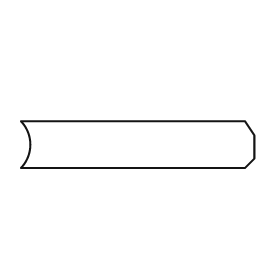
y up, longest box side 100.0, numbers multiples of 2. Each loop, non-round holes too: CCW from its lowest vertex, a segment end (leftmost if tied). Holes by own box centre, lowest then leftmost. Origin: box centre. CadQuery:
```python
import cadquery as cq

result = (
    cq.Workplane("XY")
    .moveTo(-50.0, -10.0)
    .lineTo(46.0, -10.0)
    .lineTo(50.0, -6.0)
    .lineTo(50.0, 4.0)
    .lineTo(46.0, 10.0)
    .lineTo(-50.0, 10.0)
    .threePointArc((-46.0, 0.0), (-50.0, -10.0))
    .close()
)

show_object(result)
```